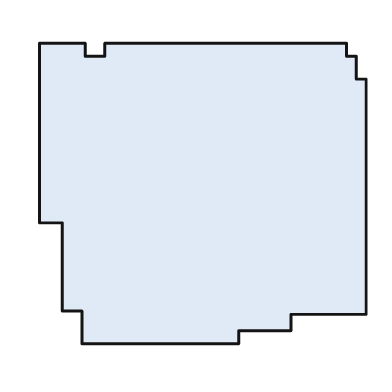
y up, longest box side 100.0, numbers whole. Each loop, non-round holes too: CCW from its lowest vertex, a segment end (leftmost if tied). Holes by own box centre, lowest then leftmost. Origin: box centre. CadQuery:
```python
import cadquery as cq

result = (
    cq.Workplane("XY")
    .moveTo(-37.0, -46.0)
    .lineTo(11.0, -46.0)
    .lineTo(11.0, -42.0)
    .lineTo(27.0, -42.0)
    .lineTo(27.0, -37.0)
    .lineTo(50.0, -37.0)
    .lineTo(50.0, 35.0)
    .lineTo(47.0, 35.0)
    .lineTo(47.0, 42.0)
    .lineTo(44.0, 42.0)
    .lineTo(44.0, 46.0)
    .lineTo(-30.0, 46.0)
    .lineTo(-30.0, 42.0)
    .lineTo(-36.0, 42.0)
    .lineTo(-36.0, 46.0)
    .lineTo(-50.0, 46.0)
    .lineTo(-50.0, -9.0)
    .lineTo(-43.0, -9.0)
    .lineTo(-43.0, -36.0)
    .lineTo(-37.0, -36.0)
    .close()
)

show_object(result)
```